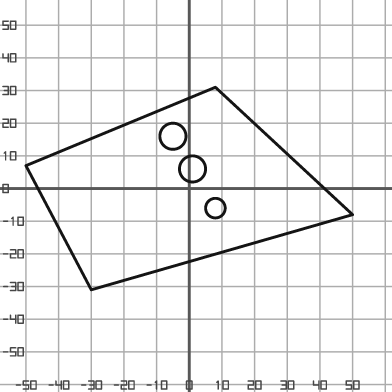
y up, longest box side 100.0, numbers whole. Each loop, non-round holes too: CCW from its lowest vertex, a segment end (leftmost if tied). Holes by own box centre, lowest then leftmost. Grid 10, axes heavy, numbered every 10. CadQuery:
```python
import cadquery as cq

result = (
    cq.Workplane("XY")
    .moveTo(-30.0, -31.0)
    .lineTo(50.0, -8.0)
    .lineTo(8.0, 31.0)
    .lineTo(-50.0, 7.0)
    .close()
    .moveTo(8.0, -6.0)
    .circle(3.0)
    .moveTo(1.0, 6.0)
    .circle(4.0)
    .moveTo(-5.0, 16.0)
    .circle(4.0)
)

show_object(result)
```